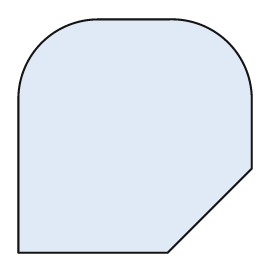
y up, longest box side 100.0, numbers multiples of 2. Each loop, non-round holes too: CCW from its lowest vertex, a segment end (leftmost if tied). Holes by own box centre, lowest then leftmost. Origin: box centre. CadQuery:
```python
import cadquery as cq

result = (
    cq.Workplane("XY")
    .moveTo(-50.0, -50.0)
    .lineTo(14.0, -50.0)
    .lineTo(50.0, -14.0)
    .lineTo(50.0, 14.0)
    .threePointArc((40.0, 40.0), (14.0, 50.0))
    .lineTo(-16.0, 50.0)
    .threePointArc((-40.0, 40.0), (-50.0, 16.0))
    .close()
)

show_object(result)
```